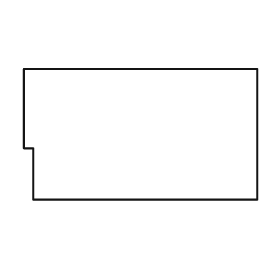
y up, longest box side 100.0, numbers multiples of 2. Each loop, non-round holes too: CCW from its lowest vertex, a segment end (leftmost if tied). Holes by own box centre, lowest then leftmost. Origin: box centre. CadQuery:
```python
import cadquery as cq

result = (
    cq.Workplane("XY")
    .moveTo(-46.0, -28.0)
    .lineTo(50.0, -28.0)
    .lineTo(50.0, 28.0)
    .lineTo(-50.0, 28.0)
    .lineTo(-50.0, -6.0)
    .lineTo(-46.0, -6.0)
    .close()
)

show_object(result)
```